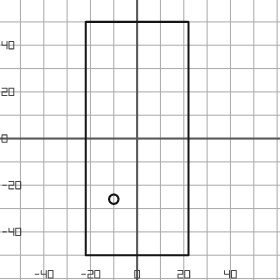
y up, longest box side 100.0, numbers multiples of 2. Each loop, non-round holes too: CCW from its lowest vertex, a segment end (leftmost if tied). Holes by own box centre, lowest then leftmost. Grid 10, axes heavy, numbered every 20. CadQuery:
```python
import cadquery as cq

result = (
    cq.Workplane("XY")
    .moveTo(-22.0, -50.0)
    .lineTo(22.0, -50.0)
    .lineTo(22.0, 50.0)
    .lineTo(-22.0, 50.0)
    .close()
    .moveTo(-10.0, -26.0)
    .circle(2.0)
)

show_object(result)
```